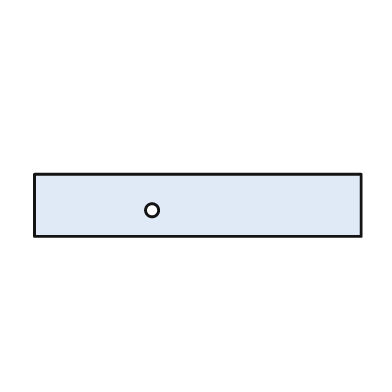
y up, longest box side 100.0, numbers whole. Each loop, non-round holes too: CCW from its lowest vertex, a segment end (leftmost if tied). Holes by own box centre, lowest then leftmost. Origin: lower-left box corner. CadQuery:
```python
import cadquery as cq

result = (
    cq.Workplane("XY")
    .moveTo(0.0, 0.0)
    .lineTo(100.0, 0.0)
    .lineTo(100.0, 19.0)
    .lineTo(0.0, 19.0)
    .close()
    .moveTo(36.0, 8.0)
    .circle(2.0)
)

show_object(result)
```